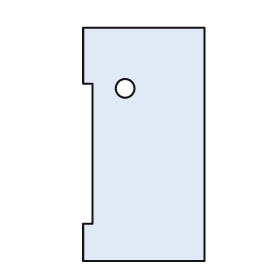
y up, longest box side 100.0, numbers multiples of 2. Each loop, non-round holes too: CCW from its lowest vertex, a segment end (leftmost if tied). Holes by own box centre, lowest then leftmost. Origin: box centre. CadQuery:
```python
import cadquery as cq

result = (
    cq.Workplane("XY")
    .moveTo(-26.0, -50.0)
    .lineTo(26.0, -50.0)
    .lineTo(26.0, 50.0)
    .lineTo(-26.0, 50.0)
    .lineTo(-26.0, 26.0)
    .lineTo(-22.0, 26.0)
    .lineTo(-22.0, -34.0)
    .lineTo(-26.0, -34.0)
    .close()
    .moveTo(-8.0, 24.0)
    .circle(4.0)
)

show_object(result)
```